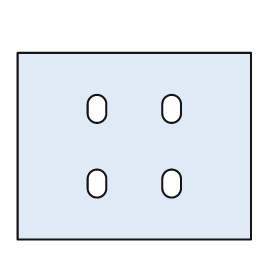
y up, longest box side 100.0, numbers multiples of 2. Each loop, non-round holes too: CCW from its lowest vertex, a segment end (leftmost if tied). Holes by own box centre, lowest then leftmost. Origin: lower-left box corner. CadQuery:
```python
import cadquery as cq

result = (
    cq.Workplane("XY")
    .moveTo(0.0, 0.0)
    .lineTo(100.0, 0.0)
    .lineTo(100.0, 80.0)
    .lineTo(0.0, 80.0)
    .close()
    .moveTo(30.0, 22.0)
    .threePointArc((34.0, 18.0), (38.0, 22.0))
    .lineTo(38.0, 26.0)
    .threePointArc((34.0, 30.0), (30.0, 26.0))
    .close()
    .moveTo(62.0, 22.0)
    .threePointArc((66.0, 18.0), (70.0, 22.0))
    .lineTo(70.0, 26.0)
    .threePointArc((66.0, 30.0), (62.0, 26.0))
    .close()
    .moveTo(30.0, 54.0)
    .threePointArc((34.0, 50.0), (38.0, 54.0))
    .lineTo(38.0, 58.0)
    .threePointArc((34.0, 62.0), (30.0, 58.0))
    .close()
    .moveTo(62.0, 54.0)
    .threePointArc((66.0, 50.0), (70.0, 54.0))
    .lineTo(70.0, 58.0)
    .threePointArc((66.0, 62.0), (62.0, 58.0))
    .close()
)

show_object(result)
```